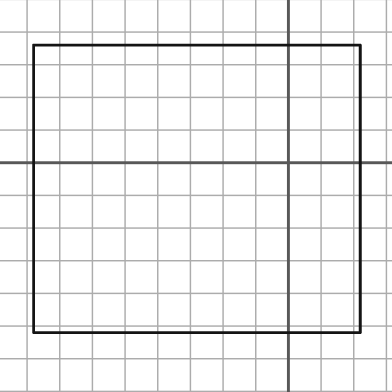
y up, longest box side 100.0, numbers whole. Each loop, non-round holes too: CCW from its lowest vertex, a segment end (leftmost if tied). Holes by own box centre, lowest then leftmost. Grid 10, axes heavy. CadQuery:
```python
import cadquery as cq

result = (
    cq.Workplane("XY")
    .moveTo(-78.0, -52.0)
    .lineTo(22.0, -52.0)
    .lineTo(22.0, 36.0)
    .lineTo(-78.0, 36.0)
    .close()
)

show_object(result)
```